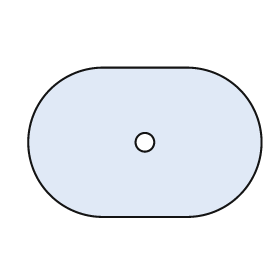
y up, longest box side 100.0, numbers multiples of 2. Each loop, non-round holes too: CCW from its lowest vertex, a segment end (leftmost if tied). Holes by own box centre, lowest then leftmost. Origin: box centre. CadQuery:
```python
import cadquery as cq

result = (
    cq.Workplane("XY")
    .moveTo(-18.0, -32.0)
    .lineTo(18.0, -32.0)
    .threePointArc((50.0, 0.0), (18.0, 32.0))
    .lineTo(-18.0, 32.0)
    .threePointArc((-50.0, 0.0), (-18.0, -32.0))
    .close()
    .moveTo(0.0, 0.0)
    .circle(4.0)
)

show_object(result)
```